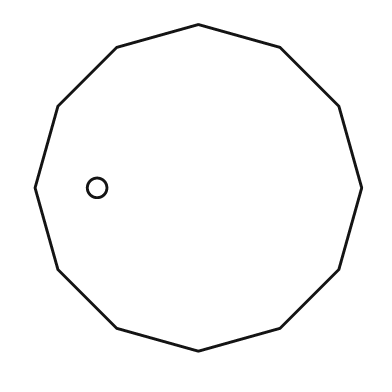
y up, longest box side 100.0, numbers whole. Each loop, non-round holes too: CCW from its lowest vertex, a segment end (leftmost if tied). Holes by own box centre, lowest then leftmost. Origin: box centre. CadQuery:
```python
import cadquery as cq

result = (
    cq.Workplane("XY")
    .moveTo(0.0, -50.0)
    .lineTo(25.0, -43.0)
    .lineTo(43.0, -25.0)
    .lineTo(50.0, 0.0)
    .lineTo(43.0, 25.0)
    .lineTo(25.0, 43.0)
    .lineTo(0.0, 50.0)
    .lineTo(-25.0, 43.0)
    .lineTo(-43.0, 25.0)
    .lineTo(-50.0, 0.0)
    .lineTo(-43.0, -25.0)
    .lineTo(-25.0, -43.0)
    .close()
    .moveTo(-31.0, 0.0)
    .circle(3.0)
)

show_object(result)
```